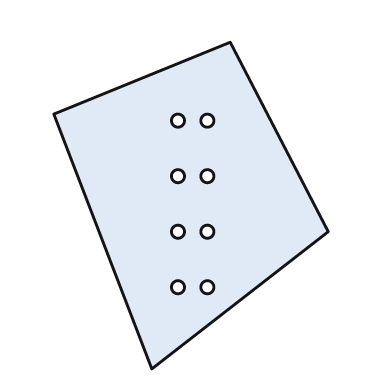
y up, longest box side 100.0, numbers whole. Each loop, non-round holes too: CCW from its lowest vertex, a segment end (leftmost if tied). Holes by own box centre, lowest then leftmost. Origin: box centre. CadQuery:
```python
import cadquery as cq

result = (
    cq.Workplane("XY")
    .moveTo(-12.0, -50.0)
    .lineTo(42.0, -8.0)
    .lineTo(12.0, 50.0)
    .lineTo(-42.0, 28.0)
    .close()
    .moveTo(-4.0, -25.0)
    .circle(2.0)
    .moveTo(5.0, -25.0)
    .circle(2.0)
    .moveTo(-4.0, -8.0)
    .circle(2.0)
    .moveTo(5.0, -8.0)
    .circle(2.0)
    .moveTo(-4.0, 9.0)
    .circle(2.0)
    .moveTo(5.0, 9.0)
    .circle(2.0)
    .moveTo(-4.0, 26.0)
    .circle(2.0)
    .moveTo(5.0, 26.0)
    .circle(2.0)
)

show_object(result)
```